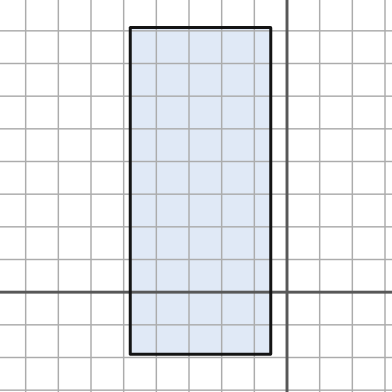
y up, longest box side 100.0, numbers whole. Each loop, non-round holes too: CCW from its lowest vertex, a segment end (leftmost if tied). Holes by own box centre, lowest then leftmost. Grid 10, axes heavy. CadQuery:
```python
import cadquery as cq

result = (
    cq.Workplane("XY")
    .moveTo(-48.0, -19.0)
    .lineTo(-5.0, -19.0)
    .lineTo(-5.0, 81.0)
    .lineTo(-48.0, 81.0)
    .close()
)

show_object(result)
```